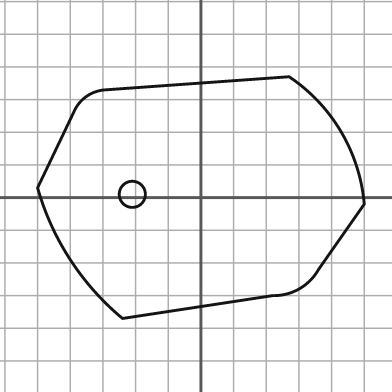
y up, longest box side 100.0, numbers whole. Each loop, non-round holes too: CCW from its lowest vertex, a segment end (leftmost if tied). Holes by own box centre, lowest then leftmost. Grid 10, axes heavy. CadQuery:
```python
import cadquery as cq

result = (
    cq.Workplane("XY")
    .moveTo(-24.0, -37.0)
    .lineTo(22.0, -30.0)
    .threePointArc((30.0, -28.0), (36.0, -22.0))
    .lineTo(50.0, -2.0)
    .threePointArc((43.0, 20.0), (27.0, 37.0))
    .lineTo(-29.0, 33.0)
    .threePointArc((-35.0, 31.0), (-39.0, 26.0))
    .lineTo(-50.0, 3.0)
    .threePointArc((-40.0, -19.0), (-24.0, -37.0))
    .close()
    .moveTo(-21.0, 1.0)
    .circle(4.0)
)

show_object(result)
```